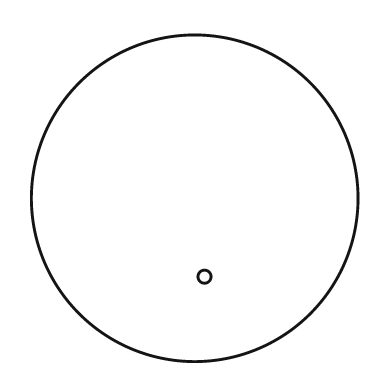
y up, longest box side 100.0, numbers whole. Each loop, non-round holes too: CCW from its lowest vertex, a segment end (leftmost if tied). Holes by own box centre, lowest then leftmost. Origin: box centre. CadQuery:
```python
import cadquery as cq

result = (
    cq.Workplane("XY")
    .moveTo(0.0, 0.0)
    .circle(50.0)
    .moveTo(3.0, -24.0)
    .circle(2.0)
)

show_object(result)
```